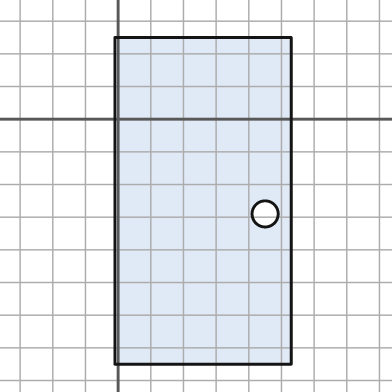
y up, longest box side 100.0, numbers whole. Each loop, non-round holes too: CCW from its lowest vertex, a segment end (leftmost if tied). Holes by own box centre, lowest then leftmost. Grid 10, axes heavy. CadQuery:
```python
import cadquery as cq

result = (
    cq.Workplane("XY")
    .moveTo(-1.0, -75.0)
    .lineTo(53.0, -75.0)
    .lineTo(53.0, 25.0)
    .lineTo(-1.0, 25.0)
    .close()
    .moveTo(45.0, -29.0)
    .circle(4.0)
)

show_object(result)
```